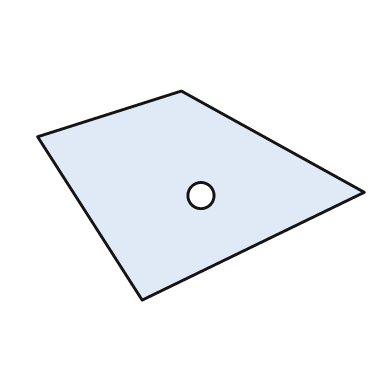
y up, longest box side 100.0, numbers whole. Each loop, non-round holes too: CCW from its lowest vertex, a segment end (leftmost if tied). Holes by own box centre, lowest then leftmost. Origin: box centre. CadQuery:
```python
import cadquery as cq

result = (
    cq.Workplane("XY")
    .moveTo(-18.0, -32.0)
    .lineTo(50.0, 1.0)
    .lineTo(-6.0, 32.0)
    .lineTo(-50.0, 18.0)
    .close()
    .moveTo(0.0, 0.0)
    .circle(4.0)
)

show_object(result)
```